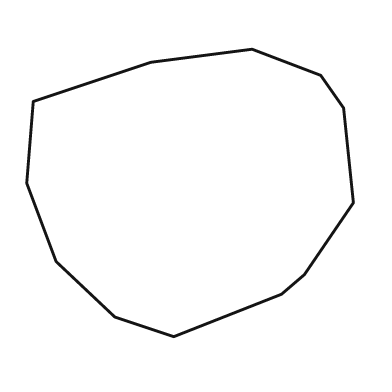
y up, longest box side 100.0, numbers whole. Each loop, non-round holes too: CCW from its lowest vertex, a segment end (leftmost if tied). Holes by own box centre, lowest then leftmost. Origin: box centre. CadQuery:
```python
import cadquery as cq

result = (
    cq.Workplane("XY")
    .moveTo(-5.0, -44.0)
    .lineTo(28.0, -31.0)
    .lineTo(35.0, -25.0)
    .lineTo(50.0, -3.0)
    .lineTo(47.0, 26.0)
    .lineTo(40.0, 36.0)
    .lineTo(19.0, 44.0)
    .lineTo(-12.0, 40.0)
    .lineTo(-48.0, 28.0)
    .lineTo(-50.0, 3.0)
    .lineTo(-41.0, -21.0)
    .lineTo(-23.0, -38.0)
    .close()
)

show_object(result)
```